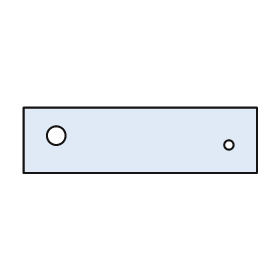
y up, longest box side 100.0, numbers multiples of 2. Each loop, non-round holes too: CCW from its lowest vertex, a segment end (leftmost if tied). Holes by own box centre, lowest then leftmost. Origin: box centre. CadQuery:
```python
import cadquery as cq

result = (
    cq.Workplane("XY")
    .moveTo(-50.0, -14.0)
    .lineTo(50.0, -14.0)
    .lineTo(50.0, 14.0)
    .lineTo(-50.0, 14.0)
    .close()
    .moveTo(38.0, -2.0)
    .circle(2.0)
    .moveTo(-36.0, 2.0)
    .circle(4.0)
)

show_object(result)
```